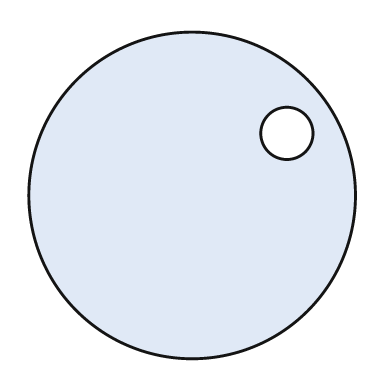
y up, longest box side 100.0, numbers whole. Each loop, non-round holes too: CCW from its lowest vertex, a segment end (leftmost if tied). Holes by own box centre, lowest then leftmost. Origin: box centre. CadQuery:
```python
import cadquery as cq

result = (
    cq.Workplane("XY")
    .moveTo(0.0, 0.0)
    .circle(50.0)
    .moveTo(29.0, 19.0)
    .circle(8.0)
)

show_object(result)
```